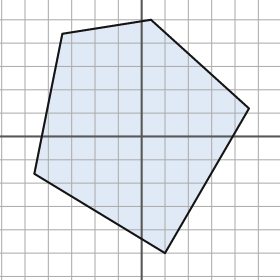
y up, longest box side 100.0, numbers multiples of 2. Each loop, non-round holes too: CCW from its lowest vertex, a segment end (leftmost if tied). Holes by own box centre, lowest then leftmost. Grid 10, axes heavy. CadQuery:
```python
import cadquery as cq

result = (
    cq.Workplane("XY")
    .moveTo(10.0, -50.0)
    .lineTo(46.0, 12.0)
    .lineTo(4.0, 50.0)
    .lineTo(-34.0, 44.0)
    .lineTo(-46.0, -16.0)
    .close()
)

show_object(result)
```